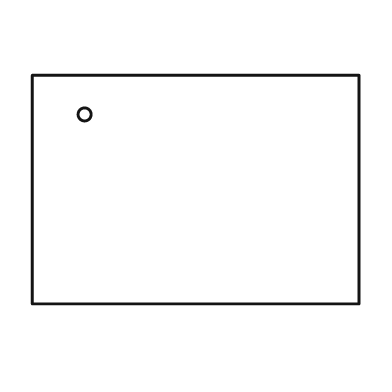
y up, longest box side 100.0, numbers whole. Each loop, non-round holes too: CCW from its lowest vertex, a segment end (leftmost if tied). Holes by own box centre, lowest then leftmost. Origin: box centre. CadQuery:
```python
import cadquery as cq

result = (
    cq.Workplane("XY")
    .moveTo(-50.0, -35.0)
    .lineTo(50.0, -35.0)
    .lineTo(50.0, 35.0)
    .lineTo(-50.0, 35.0)
    .close()
    .moveTo(-34.0, 23.0)
    .circle(2.0)
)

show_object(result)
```